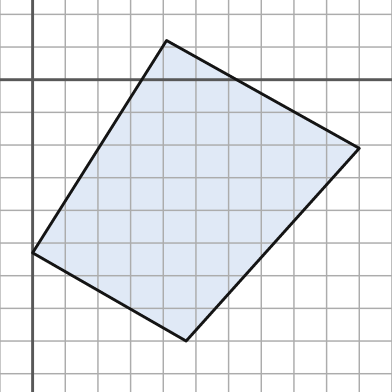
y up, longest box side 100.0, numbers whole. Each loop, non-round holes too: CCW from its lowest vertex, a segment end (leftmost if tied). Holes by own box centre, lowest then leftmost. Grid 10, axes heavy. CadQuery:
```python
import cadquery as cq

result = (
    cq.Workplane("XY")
    .moveTo(47.0, -80.0)
    .lineTo(100.0, -21.0)
    .lineTo(41.0, 12.0)
    .lineTo(0.0, -53.0)
    .close()
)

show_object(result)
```